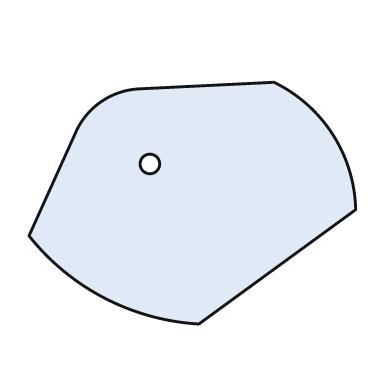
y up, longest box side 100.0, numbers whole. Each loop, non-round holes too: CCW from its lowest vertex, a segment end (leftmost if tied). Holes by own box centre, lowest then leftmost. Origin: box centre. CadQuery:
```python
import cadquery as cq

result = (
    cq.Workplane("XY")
    .moveTo(2.0, -37.0)
    .lineTo(50.0, -2.0)
    .threePointArc((43.0, 21.0), (25.0, 37.0))
    .lineTo(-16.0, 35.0)
    .threePointArc((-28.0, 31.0), (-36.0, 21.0))
    .lineTo(-50.0, -10.0)
    .threePointArc((-27.0, -29.0), (2.0, -37.0))
    .close()
    .moveTo(-13.0, 12.0)
    .circle(3.0)
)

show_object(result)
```